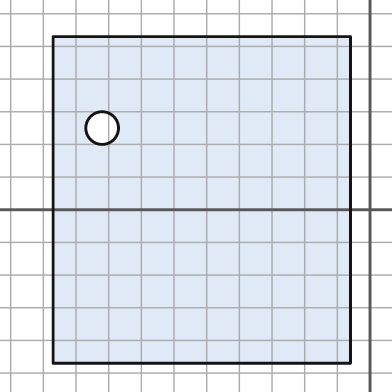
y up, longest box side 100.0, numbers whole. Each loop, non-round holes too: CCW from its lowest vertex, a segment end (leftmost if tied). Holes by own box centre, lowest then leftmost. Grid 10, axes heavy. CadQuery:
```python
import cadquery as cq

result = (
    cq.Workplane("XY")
    .moveTo(-97.0, -47.0)
    .lineTo(-6.0, -47.0)
    .lineTo(-6.0, 53.0)
    .lineTo(-97.0, 53.0)
    .close()
    .moveTo(-82.0, 25.0)
    .circle(5.0)
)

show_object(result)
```